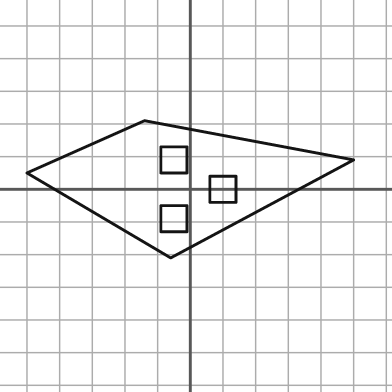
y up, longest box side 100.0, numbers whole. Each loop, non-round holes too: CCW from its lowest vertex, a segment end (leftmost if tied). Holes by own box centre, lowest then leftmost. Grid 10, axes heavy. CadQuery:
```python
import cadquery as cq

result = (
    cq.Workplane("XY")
    .moveTo(-6.0, -21.0)
    .lineTo(50.0, 9.0)
    .lineTo(-14.0, 21.0)
    .lineTo(-50.0, 5.0)
    .close()
    .moveTo(-9.0, -13.0)
    .lineTo(-1.0, -13.0)
    .lineTo(-1.0, -5.0)
    .lineTo(-9.0, -5.0)
    .close()
    .moveTo(6.0, -4.0)
    .lineTo(14.0, -4.0)
    .lineTo(14.0, 4.0)
    .lineTo(6.0, 4.0)
    .close()
    .moveTo(-9.0, 5.0)
    .lineTo(-1.0, 5.0)
    .lineTo(-1.0, 13.0)
    .lineTo(-9.0, 13.0)
    .close()
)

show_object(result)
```